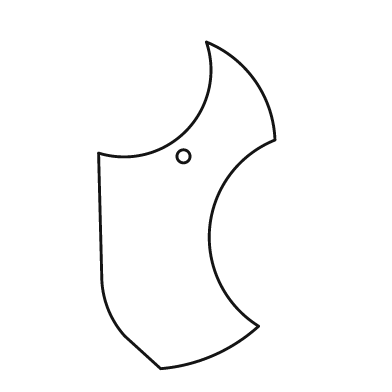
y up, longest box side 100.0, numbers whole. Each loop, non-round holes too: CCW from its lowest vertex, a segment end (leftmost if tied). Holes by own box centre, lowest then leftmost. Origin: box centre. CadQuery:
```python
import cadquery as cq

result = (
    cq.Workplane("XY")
    .moveTo(-8.0, -50.0)
    .threePointArc((8.0, -46.0), (22.0, -37.0))
    .threePointArc((7.0, -7.0), (27.0, 20.0))
    .threePointArc((21.0, 38.0), (6.0, 50.0))
    .threePointArc((0.0, 23.0), (-27.0, 16.0))
    .lineTo(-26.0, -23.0)
    .threePointArc((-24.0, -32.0), (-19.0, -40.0))
    .close()
    .moveTo(-1.0, 15.0)
    .circle(2.0)
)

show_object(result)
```